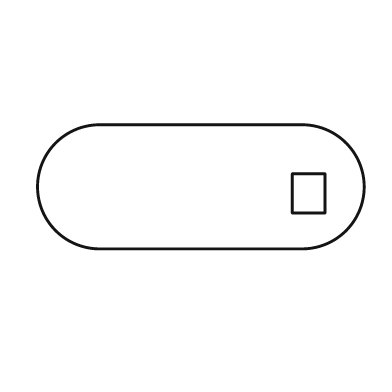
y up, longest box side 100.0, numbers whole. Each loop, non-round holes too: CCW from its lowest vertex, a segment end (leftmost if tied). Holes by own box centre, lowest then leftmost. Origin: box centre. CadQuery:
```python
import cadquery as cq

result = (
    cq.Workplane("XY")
    .moveTo(-31.0, -19.0)
    .lineTo(31.0, -19.0)
    .threePointArc((50.0, 0.0), (31.0, 19.0))
    .lineTo(-31.0, 19.0)
    .threePointArc((-50.0, 0.0), (-31.0, -19.0))
    .close()
    .moveTo(28.0, -8.0)
    .lineTo(38.0, -8.0)
    .lineTo(38.0, 4.0)
    .lineTo(28.0, 4.0)
    .close()
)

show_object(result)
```